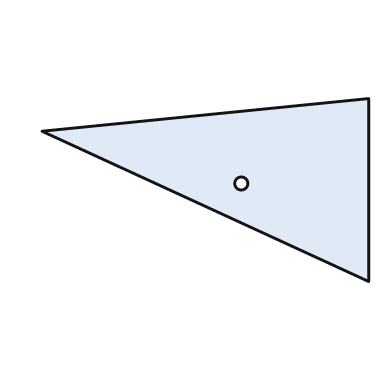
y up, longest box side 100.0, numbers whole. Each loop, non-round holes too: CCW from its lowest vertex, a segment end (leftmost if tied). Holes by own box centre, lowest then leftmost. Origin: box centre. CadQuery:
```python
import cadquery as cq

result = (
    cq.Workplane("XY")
    .moveTo(50.0, -28.0)
    .lineTo(50.0, 28.0)
    .lineTo(-50.0, 18.0)
    .close()
    .moveTo(11.0, 2.0)
    .circle(2.0)
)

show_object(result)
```